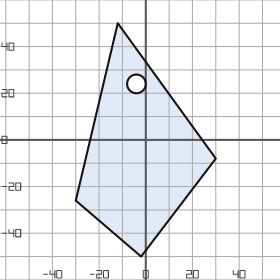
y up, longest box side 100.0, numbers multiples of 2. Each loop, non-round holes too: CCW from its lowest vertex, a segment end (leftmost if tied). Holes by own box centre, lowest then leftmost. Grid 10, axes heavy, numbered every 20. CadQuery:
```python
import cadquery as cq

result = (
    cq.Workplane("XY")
    .moveTo(-2.0, -50.0)
    .lineTo(30.0, -8.0)
    .lineTo(-12.0, 50.0)
    .lineTo(-30.0, -26.0)
    .close()
    .moveTo(-4.0, 24.0)
    .circle(4.0)
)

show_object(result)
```